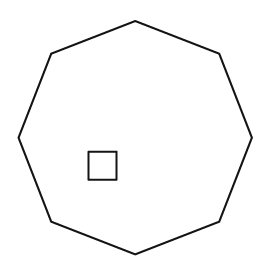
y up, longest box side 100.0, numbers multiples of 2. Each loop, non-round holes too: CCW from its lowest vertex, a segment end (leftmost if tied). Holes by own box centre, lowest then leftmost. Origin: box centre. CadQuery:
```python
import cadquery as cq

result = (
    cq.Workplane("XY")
    .moveTo(0.0, -50.0)
    .lineTo(36.0, -36.0)
    .lineTo(50.0, 0.0)
    .lineTo(36.0, 36.0)
    .lineTo(0.0, 50.0)
    .lineTo(-36.0, 36.0)
    .lineTo(-50.0, 0.0)
    .lineTo(-36.0, -36.0)
    .close()
    .moveTo(-20.0, -18.0)
    .lineTo(-8.0, -18.0)
    .lineTo(-8.0, -6.0)
    .lineTo(-20.0, -6.0)
    .close()
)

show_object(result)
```